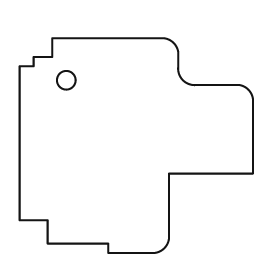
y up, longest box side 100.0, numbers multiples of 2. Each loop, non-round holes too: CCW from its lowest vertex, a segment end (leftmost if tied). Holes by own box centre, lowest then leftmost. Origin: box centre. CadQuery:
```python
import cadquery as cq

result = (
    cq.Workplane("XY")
    .moveTo(-12.0, -46.0)
    .lineTo(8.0, -46.0)
    .threePointArc((12.0, -44.0), (14.0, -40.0))
    .lineTo(14.0, -12.0)
    .lineTo(50.0, -12.0)
    .lineTo(50.0, 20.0)
    .threePointArc((48.0, 24.0), (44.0, 26.0))
    .lineTo(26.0, 26.0)
    .threePointArc((20.0, 28.0), (18.0, 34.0))
    .lineTo(18.0, 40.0)
    .threePointArc((16.0, 44.0), (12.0, 46.0))
    .lineTo(-36.0, 46.0)
    .lineTo(-36.0, 38.0)
    .lineTo(-44.0, 38.0)
    .lineTo(-44.0, 34.0)
    .lineTo(-50.0, 34.0)
    .lineTo(-50.0, -32.0)
    .lineTo(-38.0, -32.0)
    .lineTo(-38.0, -42.0)
    .lineTo(-12.0, -42.0)
    .close()
    .moveTo(-30.0, 28.0)
    .circle(4.0)
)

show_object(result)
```